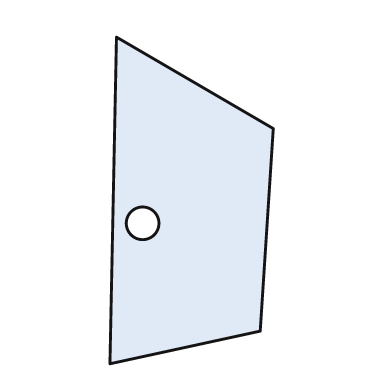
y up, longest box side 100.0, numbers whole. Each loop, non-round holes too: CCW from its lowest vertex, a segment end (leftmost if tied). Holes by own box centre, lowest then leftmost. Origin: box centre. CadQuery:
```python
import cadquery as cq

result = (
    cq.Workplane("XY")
    .moveTo(-25.0, -50.0)
    .lineTo(21.0, -40.0)
    .lineTo(25.0, 22.0)
    .lineTo(-23.0, 50.0)
    .close()
    .moveTo(-15.0, -7.0)
    .circle(5.0)
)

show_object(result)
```